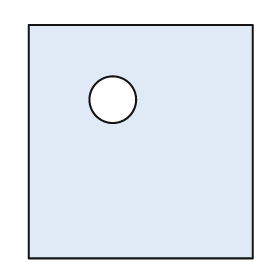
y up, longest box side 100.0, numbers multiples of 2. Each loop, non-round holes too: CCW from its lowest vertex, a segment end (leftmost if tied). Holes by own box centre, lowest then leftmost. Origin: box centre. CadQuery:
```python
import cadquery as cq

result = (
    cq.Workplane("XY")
    .moveTo(-48.0, -50.0)
    .lineTo(48.0, -50.0)
    .lineTo(48.0, 50.0)
    .lineTo(-48.0, 50.0)
    .close()
    .moveTo(-12.0, 18.0)
    .circle(10.0)
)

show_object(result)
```